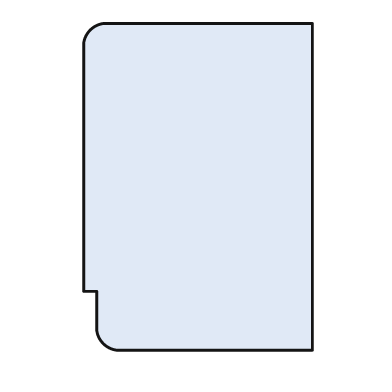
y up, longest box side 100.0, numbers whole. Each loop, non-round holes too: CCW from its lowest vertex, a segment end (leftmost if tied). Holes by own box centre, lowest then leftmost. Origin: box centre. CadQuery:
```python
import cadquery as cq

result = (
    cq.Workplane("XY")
    .moveTo(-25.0, -50.0)
    .lineTo(35.0, -50.0)
    .lineTo(35.0, 50.0)
    .lineTo(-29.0, 50.0)
    .threePointArc((-33.0, 48.0), (-35.0, 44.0))
    .lineTo(-35.0, -32.0)
    .lineTo(-31.0, -32.0)
    .lineTo(-31.0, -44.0)
    .threePointArc((-29.0, -48.0), (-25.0, -50.0))
    .close()
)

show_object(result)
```